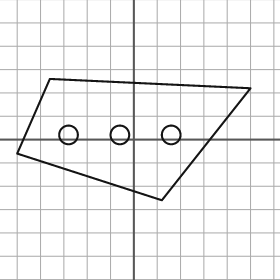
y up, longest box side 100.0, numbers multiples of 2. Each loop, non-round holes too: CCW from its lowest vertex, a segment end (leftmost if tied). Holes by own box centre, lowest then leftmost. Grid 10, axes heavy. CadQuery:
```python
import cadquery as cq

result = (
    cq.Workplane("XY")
    .moveTo(12.0, -26.0)
    .lineTo(50.0, 22.0)
    .lineTo(-36.0, 26.0)
    .lineTo(-50.0, -6.0)
    .close()
    .moveTo(-28.0, 2.0)
    .circle(4.0)
    .moveTo(-6.0, 2.0)
    .circle(4.0)
    .moveTo(16.0, 2.0)
    .circle(4.0)
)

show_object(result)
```